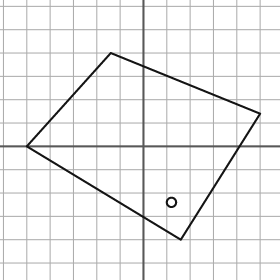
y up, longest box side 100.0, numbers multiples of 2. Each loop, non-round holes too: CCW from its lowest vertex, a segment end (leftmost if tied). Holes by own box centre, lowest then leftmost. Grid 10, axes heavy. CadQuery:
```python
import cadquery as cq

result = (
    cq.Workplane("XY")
    .moveTo(16.0, -40.0)
    .lineTo(50.0, 14.0)
    .lineTo(-14.0, 40.0)
    .lineTo(-50.0, 0.0)
    .close()
    .moveTo(12.0, -24.0)
    .circle(2.0)
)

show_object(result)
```